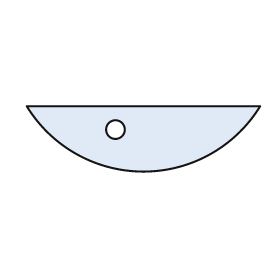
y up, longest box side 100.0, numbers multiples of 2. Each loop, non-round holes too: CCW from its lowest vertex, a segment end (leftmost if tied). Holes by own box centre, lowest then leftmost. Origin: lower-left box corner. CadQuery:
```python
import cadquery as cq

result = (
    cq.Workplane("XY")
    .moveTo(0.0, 28.0)
    .threePointArc((50.0, 0.0), (100.0, 28.0))
    .close()
    .moveTo(38.0, 18.0)
    .circle(4.0)
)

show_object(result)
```